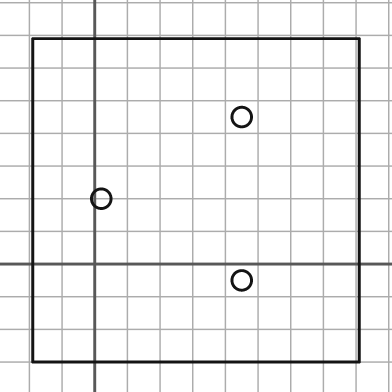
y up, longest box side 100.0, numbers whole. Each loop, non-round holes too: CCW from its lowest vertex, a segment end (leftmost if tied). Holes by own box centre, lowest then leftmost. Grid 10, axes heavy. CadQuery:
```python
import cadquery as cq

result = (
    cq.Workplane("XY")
    .moveTo(-19.0, -30.0)
    .lineTo(81.0, -30.0)
    .lineTo(81.0, 69.0)
    .lineTo(-19.0, 69.0)
    .close()
    .moveTo(45.0, -5.0)
    .circle(3.0)
    .moveTo(2.0, 20.0)
    .circle(3.0)
    .moveTo(45.0, 45.0)
    .circle(3.0)
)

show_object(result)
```